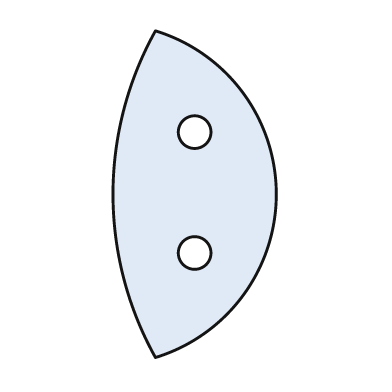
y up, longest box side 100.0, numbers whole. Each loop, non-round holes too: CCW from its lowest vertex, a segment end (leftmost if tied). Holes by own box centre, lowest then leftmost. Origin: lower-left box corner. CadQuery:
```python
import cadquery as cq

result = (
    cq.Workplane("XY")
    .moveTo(13.0, 0.0)
    .threePointArc((50.0, 50.0), (13.0, 100.0))
    .threePointArc((0.0, 50.0), (13.0, 0.0))
    .close()
    .moveTo(25.0, 32.0)
    .circle(5.0)
    .moveTo(25.0, 69.0)
    .circle(5.0)
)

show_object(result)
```